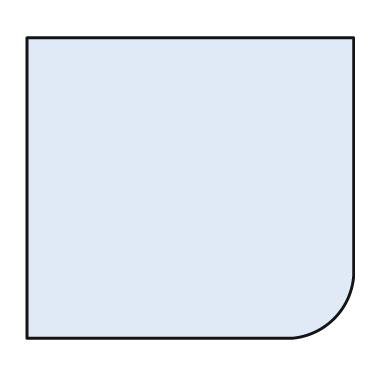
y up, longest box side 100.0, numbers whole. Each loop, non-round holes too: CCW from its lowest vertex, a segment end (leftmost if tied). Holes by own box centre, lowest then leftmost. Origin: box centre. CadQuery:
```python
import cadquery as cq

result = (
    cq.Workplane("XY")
    .moveTo(-50.0, -46.0)
    .lineTo(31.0, -46.0)
    .threePointArc((44.0, -40.0), (50.0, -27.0))
    .lineTo(50.0, 46.0)
    .lineTo(-50.0, 46.0)
    .close()
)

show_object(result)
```